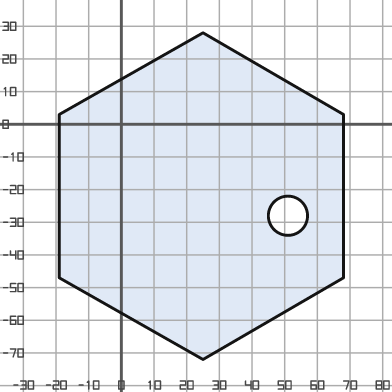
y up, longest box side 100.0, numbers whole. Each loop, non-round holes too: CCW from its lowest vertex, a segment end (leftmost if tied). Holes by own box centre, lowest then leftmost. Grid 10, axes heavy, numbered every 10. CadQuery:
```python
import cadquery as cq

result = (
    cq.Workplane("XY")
    .moveTo(25.0, -72.0)
    .lineTo(68.0, -47.0)
    .lineTo(68.0, 3.0)
    .lineTo(25.0, 28.0)
    .lineTo(-19.0, 3.0)
    .lineTo(-19.0, -47.0)
    .close()
    .moveTo(51.0, -28.0)
    .circle(6.0)
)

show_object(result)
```